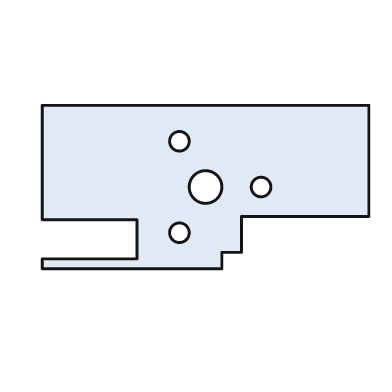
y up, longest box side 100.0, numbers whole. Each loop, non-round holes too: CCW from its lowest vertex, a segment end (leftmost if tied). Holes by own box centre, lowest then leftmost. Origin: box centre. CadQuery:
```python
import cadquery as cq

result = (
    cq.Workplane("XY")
    .moveTo(-50.0, -25.0)
    .lineTo(5.0, -25.0)
    .lineTo(5.0, -20.0)
    .lineTo(11.0, -20.0)
    .lineTo(11.0, -9.0)
    .lineTo(50.0, -9.0)
    .lineTo(50.0, 25.0)
    .lineTo(-50.0, 25.0)
    .lineTo(-50.0, -10.0)
    .lineTo(-21.0, -10.0)
    .lineTo(-21.0, -22.0)
    .lineTo(-50.0, -22.0)
    .close()
    .moveTo(-8.0, -14.0)
    .circle(3.0)
    .moveTo(0.0, 0.0)
    .circle(5.0)
    .moveTo(17.0, 0.0)
    .circle(3.0)
    .moveTo(-8.0, 14.0)
    .circle(3.0)
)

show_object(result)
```